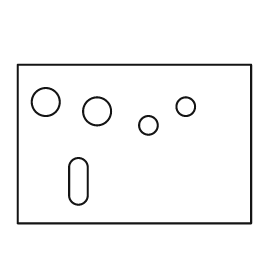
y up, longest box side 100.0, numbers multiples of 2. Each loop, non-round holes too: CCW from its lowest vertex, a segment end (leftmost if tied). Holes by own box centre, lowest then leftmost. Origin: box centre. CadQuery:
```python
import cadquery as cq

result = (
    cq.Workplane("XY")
    .moveTo(-50.0, -34.0)
    .lineTo(50.0, -34.0)
    .lineTo(50.0, 34.0)
    .lineTo(-50.0, 34.0)
    .close()
    .moveTo(-28.0, -22.0)
    .threePointArc((-24.0, -26.0), (-20.0, -22.0))
    .lineTo(-20.0, -10.0)
    .threePointArc((-24.0, -6.0), (-28.0, -10.0))
    .close()
    .moveTo(6.0, 8.0)
    .circle(4.0)
    .moveTo(-16.0, 14.0)
    .circle(6.0)
    .moveTo(22.0, 16.0)
    .circle(4.0)
    .moveTo(-38.0, 18.0)
    .circle(6.0)
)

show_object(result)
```